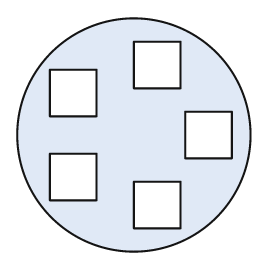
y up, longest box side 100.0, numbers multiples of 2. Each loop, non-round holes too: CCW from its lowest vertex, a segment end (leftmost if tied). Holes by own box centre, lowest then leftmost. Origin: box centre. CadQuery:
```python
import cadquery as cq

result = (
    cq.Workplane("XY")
    .moveTo(0.0, 0.0)
    .circle(50.0)
    .moveTo(0.0, -40.0)
    .lineTo(20.0, -40.0)
    .lineTo(20.0, -20.0)
    .lineTo(0.0, -20.0)
    .close()
    .moveTo(-36.0, -28.0)
    .lineTo(-16.0, -28.0)
    .lineTo(-16.0, -8.0)
    .lineTo(-36.0, -8.0)
    .close()
    .moveTo(22.0, -10.0)
    .lineTo(42.0, -10.0)
    .lineTo(42.0, 10.0)
    .lineTo(22.0, 10.0)
    .close()
    .moveTo(-36.0, 8.0)
    .lineTo(-16.0, 8.0)
    .lineTo(-16.0, 28.0)
    .lineTo(-36.0, 28.0)
    .close()
    .moveTo(0.0, 20.0)
    .lineTo(20.0, 20.0)
    .lineTo(20.0, 40.0)
    .lineTo(0.0, 40.0)
    .close()
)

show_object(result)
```